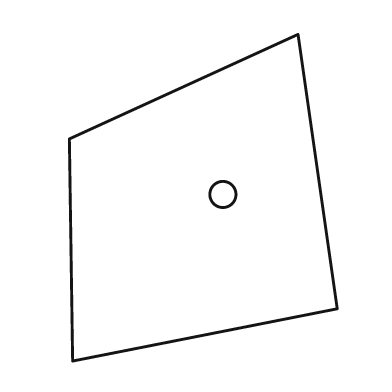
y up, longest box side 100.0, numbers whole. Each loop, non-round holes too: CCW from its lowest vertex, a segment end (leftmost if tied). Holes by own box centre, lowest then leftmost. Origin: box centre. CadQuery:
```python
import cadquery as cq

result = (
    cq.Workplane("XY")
    .moveTo(-40.0, -50.0)
    .lineTo(41.0, -34.0)
    .lineTo(29.0, 50.0)
    .lineTo(-41.0, 18.0)
    .close()
    .moveTo(6.0, 1.0)
    .circle(4.0)
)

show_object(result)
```